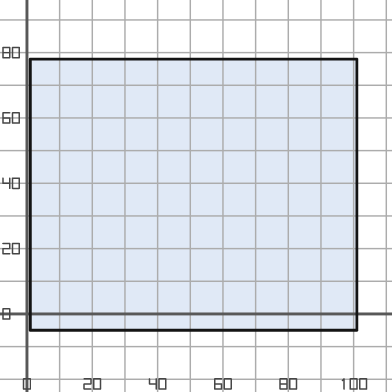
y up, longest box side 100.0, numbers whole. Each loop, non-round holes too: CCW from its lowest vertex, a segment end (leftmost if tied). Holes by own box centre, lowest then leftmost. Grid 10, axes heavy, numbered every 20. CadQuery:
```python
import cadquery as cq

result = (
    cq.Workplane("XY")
    .moveTo(1.0, -5.0)
    .lineTo(101.0, -5.0)
    .lineTo(101.0, 78.0)
    .lineTo(1.0, 78.0)
    .close()
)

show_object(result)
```